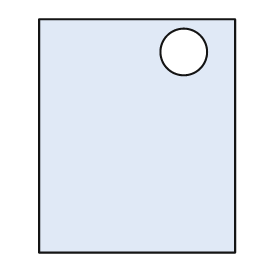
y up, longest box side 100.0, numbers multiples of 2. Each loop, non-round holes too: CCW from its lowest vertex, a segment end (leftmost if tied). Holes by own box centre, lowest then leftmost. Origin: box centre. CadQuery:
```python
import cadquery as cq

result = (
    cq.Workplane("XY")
    .moveTo(-42.0, -50.0)
    .lineTo(42.0, -50.0)
    .lineTo(42.0, 50.0)
    .lineTo(-42.0, 50.0)
    .close()
    .moveTo(20.0, 36.0)
    .circle(10.0)
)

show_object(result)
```